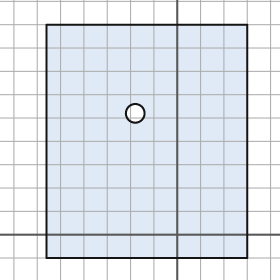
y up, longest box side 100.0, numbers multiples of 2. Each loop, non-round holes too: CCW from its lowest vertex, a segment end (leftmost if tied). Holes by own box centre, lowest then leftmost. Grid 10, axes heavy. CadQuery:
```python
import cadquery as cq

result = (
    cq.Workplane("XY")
    .moveTo(-56.0, -10.0)
    .lineTo(30.0, -10.0)
    .lineTo(30.0, 90.0)
    .lineTo(-56.0, 90.0)
    .close()
    .moveTo(-18.0, 52.0)
    .circle(4.0)
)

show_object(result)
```